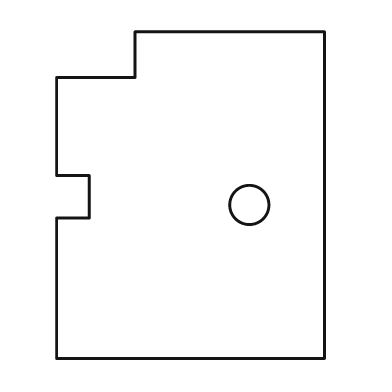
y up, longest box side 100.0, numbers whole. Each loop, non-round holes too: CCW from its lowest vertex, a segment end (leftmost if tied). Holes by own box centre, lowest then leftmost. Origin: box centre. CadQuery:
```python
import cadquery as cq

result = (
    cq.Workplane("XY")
    .moveTo(-41.0, -50.0)
    .lineTo(41.0, -50.0)
    .lineTo(41.0, 50.0)
    .lineTo(-17.0, 50.0)
    .lineTo(-17.0, 36.0)
    .lineTo(-41.0, 36.0)
    .lineTo(-41.0, 6.0)
    .lineTo(-31.0, 6.0)
    .lineTo(-31.0, -7.0)
    .lineTo(-41.0, -7.0)
    .close()
    .moveTo(18.0, -3.0)
    .circle(6.0)
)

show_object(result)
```